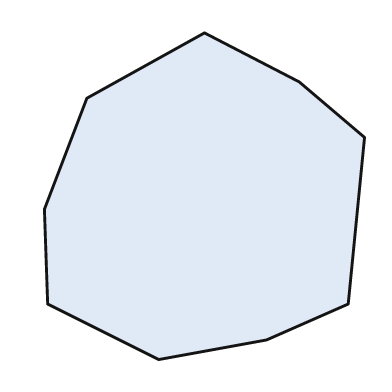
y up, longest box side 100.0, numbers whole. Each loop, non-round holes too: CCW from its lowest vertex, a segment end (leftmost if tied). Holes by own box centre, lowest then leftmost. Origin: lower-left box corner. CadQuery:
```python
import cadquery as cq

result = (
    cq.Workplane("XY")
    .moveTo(35.0, 0.0)
    .lineTo(68.0, 6.0)
    .lineTo(93.0, 17.0)
    .lineTo(98.0, 68.0)
    .lineTo(78.0, 85.0)
    .lineTo(49.0, 100.0)
    .lineTo(13.0, 80.0)
    .lineTo(0.0, 46.0)
    .lineTo(1.0, 17.0)
    .close()
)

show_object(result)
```